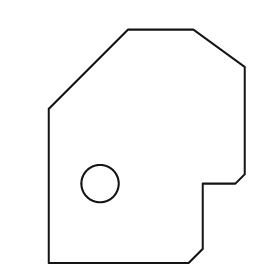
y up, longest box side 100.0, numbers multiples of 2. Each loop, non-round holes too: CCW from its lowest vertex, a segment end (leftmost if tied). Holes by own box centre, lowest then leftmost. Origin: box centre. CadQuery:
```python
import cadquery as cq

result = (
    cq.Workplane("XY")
    .moveTo(-42.0, -50.0)
    .lineTo(18.0, -50.0)
    .lineTo(24.0, -44.0)
    .lineTo(24.0, -16.0)
    .lineTo(38.0, -16.0)
    .lineTo(42.0, -12.0)
    .lineTo(42.0, 34.0)
    .lineTo(20.0, 50.0)
    .lineTo(-8.0, 50.0)
    .lineTo(-42.0, 16.0)
    .close()
    .moveTo(-20.0, -16.0)
    .circle(8.0)
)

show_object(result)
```